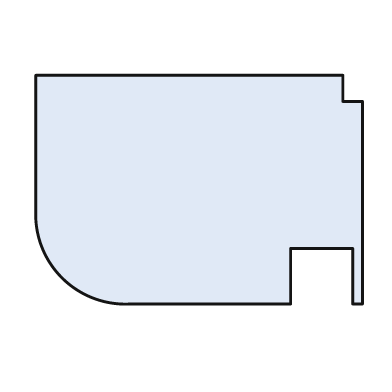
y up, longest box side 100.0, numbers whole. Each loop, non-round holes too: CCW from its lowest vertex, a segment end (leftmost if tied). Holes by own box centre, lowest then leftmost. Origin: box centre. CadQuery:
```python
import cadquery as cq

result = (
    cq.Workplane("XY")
    .moveTo(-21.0, -35.0)
    .lineTo(28.0, -35.0)
    .lineTo(28.0, -18.0)
    .lineTo(47.0, -18.0)
    .lineTo(47.0, -35.0)
    .lineTo(50.0, -35.0)
    .lineTo(50.0, 27.0)
    .lineTo(44.0, 27.0)
    .lineTo(44.0, 35.0)
    .lineTo(-50.0, 35.0)
    .lineTo(-50.0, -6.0)
    .threePointArc((-42.0, -27.0), (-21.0, -35.0))
    .close()
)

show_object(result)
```